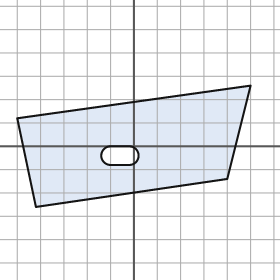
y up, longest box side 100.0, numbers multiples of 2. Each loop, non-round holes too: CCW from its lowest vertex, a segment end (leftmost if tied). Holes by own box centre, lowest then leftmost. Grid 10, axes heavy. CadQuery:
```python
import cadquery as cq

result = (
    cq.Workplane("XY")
    .moveTo(-42.0, -26.0)
    .lineTo(40.0, -14.0)
    .lineTo(50.0, 26.0)
    .lineTo(-50.0, 12.0)
    .close()
    .moveTo(-10.0, -8.0)
    .lineTo(-2.0, -8.0)
    .threePointArc((2.0, -4.0), (-2.0, 0.0))
    .lineTo(-10.0, 0.0)
    .threePointArc((-14.0, -4.0), (-10.0, -8.0))
    .close()
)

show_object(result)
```